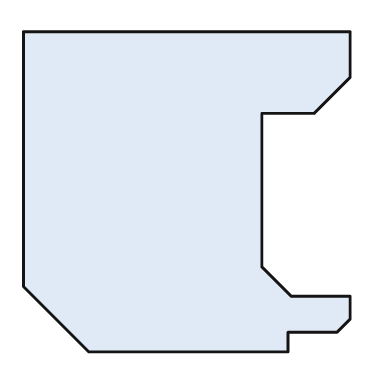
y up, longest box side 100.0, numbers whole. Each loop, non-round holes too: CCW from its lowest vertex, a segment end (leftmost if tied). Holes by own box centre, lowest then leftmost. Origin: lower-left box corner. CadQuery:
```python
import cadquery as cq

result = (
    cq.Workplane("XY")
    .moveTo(20.0, 0.0)
    .lineTo(81.0, 0.0)
    .lineTo(81.0, 6.0)
    .lineTo(96.0, 6.0)
    .lineTo(100.0, 10.0)
    .lineTo(100.0, 17.0)
    .lineTo(82.0, 17.0)
    .lineTo(73.0, 26.0)
    .lineTo(73.0, 73.0)
    .lineTo(89.0, 73.0)
    .lineTo(100.0, 84.0)
    .lineTo(100.0, 98.0)
    .lineTo(0.0, 98.0)
    .lineTo(0.0, 20.0)
    .close()
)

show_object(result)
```